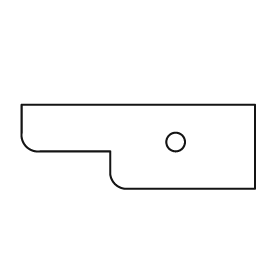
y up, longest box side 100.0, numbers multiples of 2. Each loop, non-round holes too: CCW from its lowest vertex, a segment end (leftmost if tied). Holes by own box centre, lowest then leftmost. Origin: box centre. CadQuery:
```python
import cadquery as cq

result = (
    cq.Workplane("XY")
    .moveTo(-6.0, -18.0)
    .lineTo(50.0, -18.0)
    .lineTo(50.0, 18.0)
    .lineTo(-50.0, 18.0)
    .lineTo(-50.0, 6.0)
    .threePointArc((-48.0, 0.0), (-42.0, -2.0))
    .lineTo(-12.0, -2.0)
    .lineTo(-12.0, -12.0)
    .threePointArc((-10.0, -16.0), (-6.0, -18.0))
    .close()
    .moveTo(16.0, 2.0)
    .circle(4.0)
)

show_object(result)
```